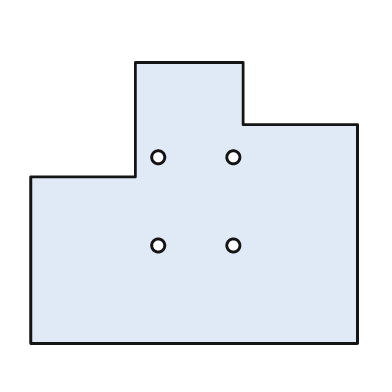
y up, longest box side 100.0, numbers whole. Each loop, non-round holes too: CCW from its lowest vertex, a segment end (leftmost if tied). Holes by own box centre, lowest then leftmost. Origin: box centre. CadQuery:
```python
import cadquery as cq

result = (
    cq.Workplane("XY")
    .moveTo(-50.0, -43.0)
    .lineTo(50.0, -43.0)
    .lineTo(50.0, 24.0)
    .lineTo(15.0, 24.0)
    .lineTo(15.0, 43.0)
    .lineTo(-18.0, 43.0)
    .lineTo(-18.0, 8.0)
    .lineTo(-50.0, 8.0)
    .close()
    .moveTo(-11.0, -13.0)
    .circle(2.0)
    .moveTo(12.0, -13.0)
    .circle(2.0)
    .moveTo(-11.0, 14.0)
    .circle(2.0)
    .moveTo(12.0, 14.0)
    .circle(2.0)
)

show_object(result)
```